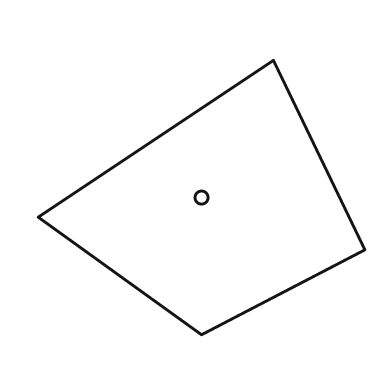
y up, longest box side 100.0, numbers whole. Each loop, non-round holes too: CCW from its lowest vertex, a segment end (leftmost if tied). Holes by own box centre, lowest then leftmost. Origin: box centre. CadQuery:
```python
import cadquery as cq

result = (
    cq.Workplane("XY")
    .moveTo(0.0, -42.0)
    .lineTo(50.0, -16.0)
    .lineTo(22.0, 42.0)
    .lineTo(-50.0, -6.0)
    .close()
    .moveTo(0.0, 0.0)
    .circle(2.0)
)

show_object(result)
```